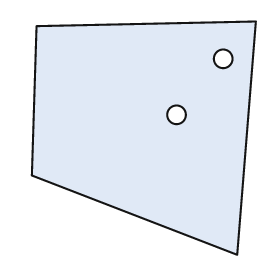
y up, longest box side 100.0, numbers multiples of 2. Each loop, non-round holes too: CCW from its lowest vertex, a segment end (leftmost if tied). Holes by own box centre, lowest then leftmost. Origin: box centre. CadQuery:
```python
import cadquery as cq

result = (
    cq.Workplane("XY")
    .moveTo(40.0, -50.0)
    .lineTo(48.0, 50.0)
    .lineTo(-46.0, 48.0)
    .lineTo(-48.0, -16.0)
    .close()
    .moveTo(14.0, 10.0)
    .circle(4.0)
    .moveTo(34.0, 34.0)
    .circle(4.0)
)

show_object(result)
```